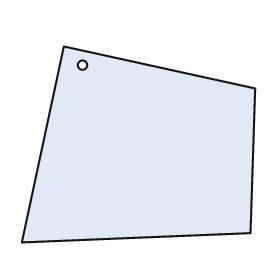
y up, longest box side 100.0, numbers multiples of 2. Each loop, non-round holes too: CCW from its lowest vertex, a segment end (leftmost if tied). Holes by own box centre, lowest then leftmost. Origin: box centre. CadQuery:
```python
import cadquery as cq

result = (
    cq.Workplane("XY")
    .moveTo(-50.0, -42.0)
    .lineTo(48.0, -38.0)
    .lineTo(50.0, 24.0)
    .lineTo(-32.0, 42.0)
    .close()
    .moveTo(-24.0, 34.0)
    .circle(2.0)
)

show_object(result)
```